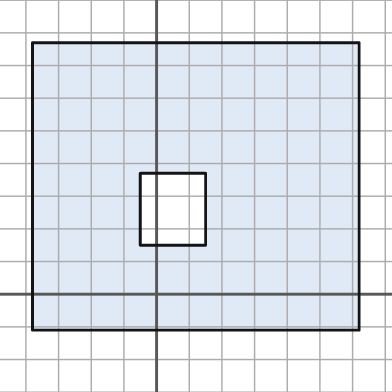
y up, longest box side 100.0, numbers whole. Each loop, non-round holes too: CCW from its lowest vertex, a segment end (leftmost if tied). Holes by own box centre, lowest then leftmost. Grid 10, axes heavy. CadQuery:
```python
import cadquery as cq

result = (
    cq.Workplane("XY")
    .moveTo(-38.0, -11.0)
    .lineTo(62.0, -11.0)
    .lineTo(62.0, 77.0)
    .lineTo(-38.0, 77.0)
    .close()
    .moveTo(-5.0, 15.0)
    .lineTo(15.0, 15.0)
    .lineTo(15.0, 37.0)
    .lineTo(-5.0, 37.0)
    .close()
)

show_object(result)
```